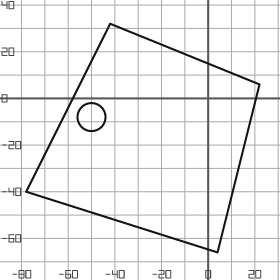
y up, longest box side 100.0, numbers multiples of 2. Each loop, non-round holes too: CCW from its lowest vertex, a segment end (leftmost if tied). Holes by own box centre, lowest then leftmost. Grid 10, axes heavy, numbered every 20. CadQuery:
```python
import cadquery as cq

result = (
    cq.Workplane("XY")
    .moveTo(4.0, -66.0)
    .lineTo(22.0, 6.0)
    .lineTo(-42.0, 32.0)
    .lineTo(-78.0, -40.0)
    .close()
    .moveTo(-50.0, -8.0)
    .circle(6.0)
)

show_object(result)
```